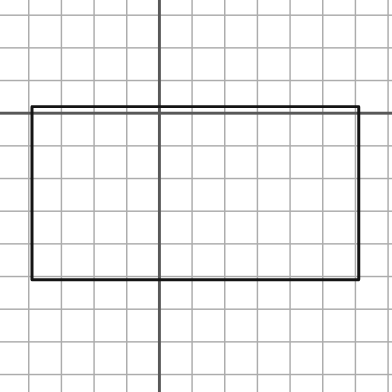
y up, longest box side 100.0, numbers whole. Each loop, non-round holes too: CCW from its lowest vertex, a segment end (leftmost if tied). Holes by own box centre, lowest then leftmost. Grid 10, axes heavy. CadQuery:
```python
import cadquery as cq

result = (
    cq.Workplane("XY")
    .moveTo(-39.0, -51.0)
    .lineTo(61.0, -51.0)
    .lineTo(61.0, 2.0)
    .lineTo(-39.0, 2.0)
    .close()
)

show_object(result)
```